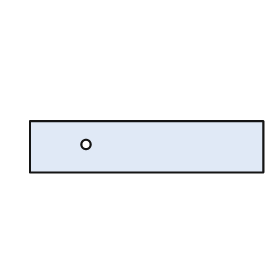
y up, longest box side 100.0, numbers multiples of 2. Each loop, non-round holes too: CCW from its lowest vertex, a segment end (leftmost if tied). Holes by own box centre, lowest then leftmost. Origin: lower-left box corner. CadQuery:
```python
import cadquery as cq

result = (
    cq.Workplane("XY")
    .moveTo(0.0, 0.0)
    .lineTo(100.0, 0.0)
    .lineTo(100.0, 22.0)
    .lineTo(0.0, 22.0)
    .close()
    .moveTo(24.0, 12.0)
    .circle(2.0)
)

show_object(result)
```